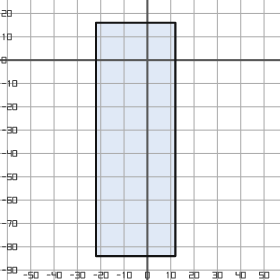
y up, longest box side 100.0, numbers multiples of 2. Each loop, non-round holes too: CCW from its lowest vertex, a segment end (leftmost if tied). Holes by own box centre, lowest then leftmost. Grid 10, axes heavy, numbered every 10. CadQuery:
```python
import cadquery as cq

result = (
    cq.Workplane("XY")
    .moveTo(-22.0, -84.0)
    .lineTo(12.0, -84.0)
    .lineTo(12.0, 16.0)
    .lineTo(-22.0, 16.0)
    .close()
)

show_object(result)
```